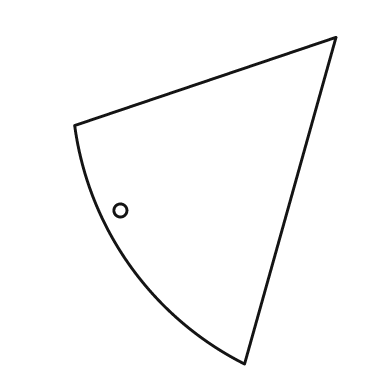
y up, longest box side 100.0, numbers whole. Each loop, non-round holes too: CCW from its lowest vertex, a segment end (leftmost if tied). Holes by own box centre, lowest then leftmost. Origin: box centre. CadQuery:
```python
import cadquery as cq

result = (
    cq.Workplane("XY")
    .moveTo(12.0, -50.0)
    .lineTo(40.0, 50.0)
    .lineTo(-40.0, 23.0)
    .threePointArc((-23.0, -20.0), (12.0, -50.0))
    .close()
    .moveTo(-26.0, -3.0)
    .circle(2.0)
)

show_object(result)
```